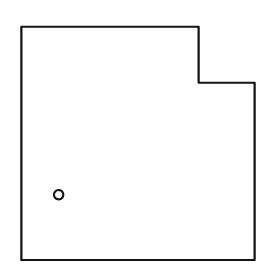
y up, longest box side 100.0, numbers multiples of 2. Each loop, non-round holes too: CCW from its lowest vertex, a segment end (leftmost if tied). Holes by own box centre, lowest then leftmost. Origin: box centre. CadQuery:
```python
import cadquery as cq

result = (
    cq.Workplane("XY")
    .moveTo(-50.0, -50.0)
    .lineTo(50.0, -50.0)
    .lineTo(50.0, 26.0)
    .lineTo(26.0, 26.0)
    .lineTo(26.0, 50.0)
    .lineTo(-50.0, 50.0)
    .close()
    .moveTo(-34.0, -22.0)
    .circle(2.0)
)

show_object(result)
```